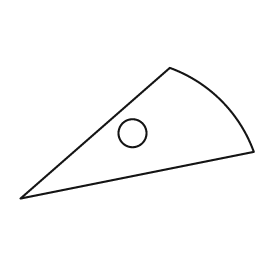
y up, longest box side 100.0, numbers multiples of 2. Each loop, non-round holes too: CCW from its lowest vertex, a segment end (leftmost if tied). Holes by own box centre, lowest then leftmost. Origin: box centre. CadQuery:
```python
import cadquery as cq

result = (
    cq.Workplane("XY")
    .moveTo(-50.0, -28.0)
    .lineTo(50.0, -8.0)
    .threePointArc((36.0, 14.0), (14.0, 28.0))
    .close()
    .moveTo(-2.0, 0.0)
    .circle(6.0)
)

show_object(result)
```